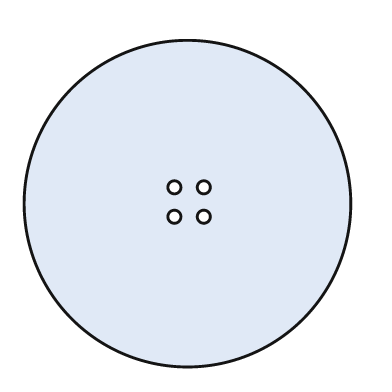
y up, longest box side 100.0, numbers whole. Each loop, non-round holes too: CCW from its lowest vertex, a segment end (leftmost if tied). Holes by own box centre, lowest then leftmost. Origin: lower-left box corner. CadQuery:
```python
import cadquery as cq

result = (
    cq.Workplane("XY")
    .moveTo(50.0, 50.0)
    .circle(50.0)
    .moveTo(46.0, 46.0)
    .circle(2.0)
    .moveTo(55.0, 46.0)
    .circle(2.0)
    .moveTo(46.0, 55.0)
    .circle(2.0)
    .moveTo(55.0, 55.0)
    .circle(2.0)
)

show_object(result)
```